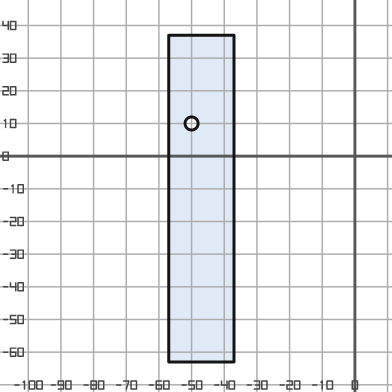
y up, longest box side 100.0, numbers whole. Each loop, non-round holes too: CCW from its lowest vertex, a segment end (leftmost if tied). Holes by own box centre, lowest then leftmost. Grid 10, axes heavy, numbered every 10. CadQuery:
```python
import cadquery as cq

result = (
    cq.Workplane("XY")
    .moveTo(-57.0, -63.0)
    .lineTo(-37.0, -63.0)
    .lineTo(-37.0, 37.0)
    .lineTo(-57.0, 37.0)
    .close()
    .moveTo(-50.0, 10.0)
    .circle(2.0)
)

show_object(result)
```